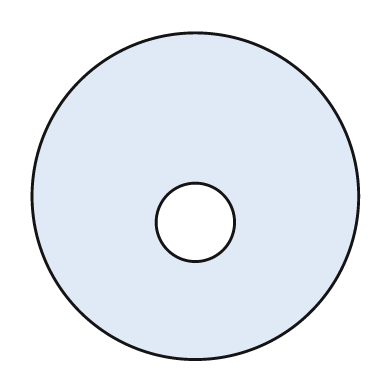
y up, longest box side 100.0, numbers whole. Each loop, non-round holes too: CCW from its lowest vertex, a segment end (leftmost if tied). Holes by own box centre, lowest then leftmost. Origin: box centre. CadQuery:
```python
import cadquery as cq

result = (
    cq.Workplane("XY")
    .moveTo(0.0, 0.0)
    .circle(50.0)
    .moveTo(0.0, -8.0)
    .circle(12.0)
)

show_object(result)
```